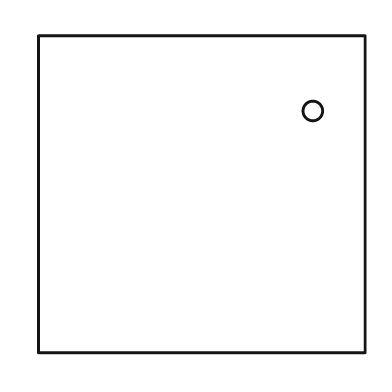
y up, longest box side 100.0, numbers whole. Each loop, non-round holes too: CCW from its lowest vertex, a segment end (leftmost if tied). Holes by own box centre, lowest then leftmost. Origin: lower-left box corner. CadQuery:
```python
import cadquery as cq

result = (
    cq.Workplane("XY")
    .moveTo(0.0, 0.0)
    .lineTo(100.0, 0.0)
    .lineTo(100.0, 97.0)
    .lineTo(0.0, 97.0)
    .close()
    .moveTo(84.0, 74.0)
    .circle(3.0)
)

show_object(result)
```